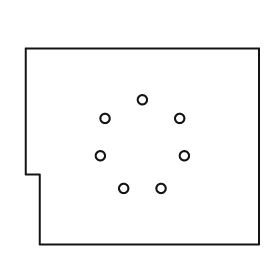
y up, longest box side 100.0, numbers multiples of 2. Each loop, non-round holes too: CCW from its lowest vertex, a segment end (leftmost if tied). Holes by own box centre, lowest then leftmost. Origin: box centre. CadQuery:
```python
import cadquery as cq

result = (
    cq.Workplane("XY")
    .moveTo(-44.0, -42.0)
    .lineTo(50.0, -42.0)
    .lineTo(50.0, 42.0)
    .lineTo(-50.0, 42.0)
    .lineTo(-50.0, -12.0)
    .lineTo(-44.0, -12.0)
    .close()
    .moveTo(-8.0, -18.0)
    .circle(2.0)
    .moveTo(8.0, -18.0)
    .circle(2.0)
    .moveTo(-18.0, -4.0)
    .circle(2.0)
    .moveTo(18.0, -4.0)
    .circle(2.0)
    .moveTo(-16.0, 12.0)
    .circle(2.0)
    .moveTo(16.0, 12.0)
    .circle(2.0)
    .moveTo(0.0, 20.0)
    .circle(2.0)
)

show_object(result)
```